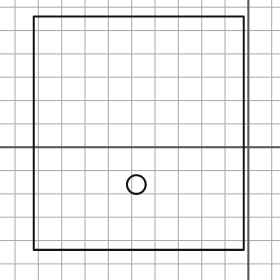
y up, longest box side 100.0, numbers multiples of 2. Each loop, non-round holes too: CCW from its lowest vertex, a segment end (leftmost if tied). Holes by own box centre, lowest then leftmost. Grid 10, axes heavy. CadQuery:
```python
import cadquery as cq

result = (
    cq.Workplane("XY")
    .moveTo(-92.0, -44.0)
    .lineTo(-2.0, -44.0)
    .lineTo(-2.0, 56.0)
    .lineTo(-92.0, 56.0)
    .close()
    .moveTo(-48.0, -16.0)
    .circle(4.0)
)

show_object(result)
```